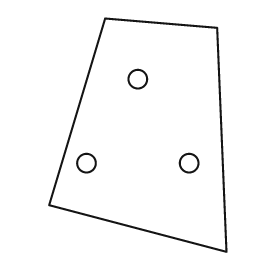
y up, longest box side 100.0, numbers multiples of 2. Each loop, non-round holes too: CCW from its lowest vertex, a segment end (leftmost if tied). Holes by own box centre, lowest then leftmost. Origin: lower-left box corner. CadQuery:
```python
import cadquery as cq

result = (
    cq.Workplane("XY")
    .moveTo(76.0, 0.0)
    .lineTo(72.0, 96.0)
    .lineTo(24.0, 100.0)
    .lineTo(0.0, 20.0)
    .close()
    .moveTo(16.0, 38.0)
    .circle(4.0)
    .moveTo(60.0, 38.0)
    .circle(4.0)
    .moveTo(38.0, 74.0)
    .circle(4.0)
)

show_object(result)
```